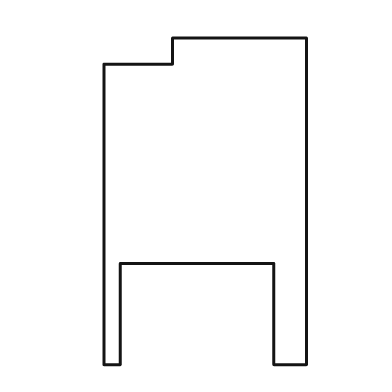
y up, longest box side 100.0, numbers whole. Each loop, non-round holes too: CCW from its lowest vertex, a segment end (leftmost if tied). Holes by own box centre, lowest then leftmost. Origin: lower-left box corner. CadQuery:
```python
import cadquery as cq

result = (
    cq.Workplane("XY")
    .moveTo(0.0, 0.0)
    .lineTo(5.0, 0.0)
    .lineTo(5.0, 31.0)
    .lineTo(52.0, 31.0)
    .lineTo(52.0, 0.0)
    .lineTo(62.0, 0.0)
    .lineTo(62.0, 100.0)
    .lineTo(21.0, 100.0)
    .lineTo(21.0, 92.0)
    .lineTo(0.0, 92.0)
    .close()
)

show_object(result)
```